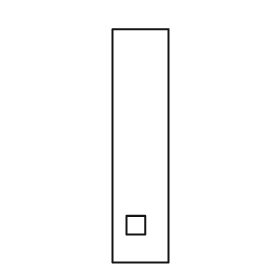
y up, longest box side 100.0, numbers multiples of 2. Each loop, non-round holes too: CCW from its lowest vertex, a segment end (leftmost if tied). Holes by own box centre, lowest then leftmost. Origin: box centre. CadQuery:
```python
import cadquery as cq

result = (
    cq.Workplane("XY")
    .moveTo(-12.0, -50.0)
    .lineTo(12.0, -50.0)
    .lineTo(12.0, 50.0)
    .lineTo(-12.0, 50.0)
    .close()
    .moveTo(-6.0, -38.0)
    .lineTo(2.0, -38.0)
    .lineTo(2.0, -30.0)
    .lineTo(-6.0, -30.0)
    .close()
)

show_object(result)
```